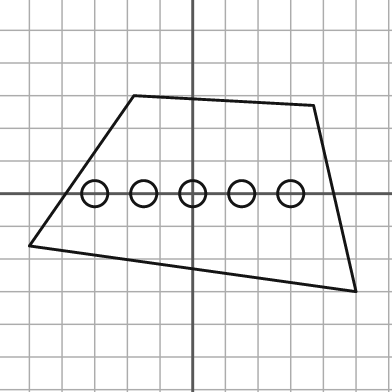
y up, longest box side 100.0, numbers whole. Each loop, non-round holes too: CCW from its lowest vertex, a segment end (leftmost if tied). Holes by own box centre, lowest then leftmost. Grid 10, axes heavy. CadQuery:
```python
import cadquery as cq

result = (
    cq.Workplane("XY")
    .moveTo(50.0, -30.0)
    .lineTo(37.0, 27.0)
    .lineTo(-18.0, 30.0)
    .lineTo(-50.0, -16.0)
    .close()
    .moveTo(-30.0, 0.0)
    .circle(4.0)
    .moveTo(-15.0, 0.0)
    .circle(4.0)
    .moveTo(0.0, 0.0)
    .circle(4.0)
    .moveTo(15.0, 0.0)
    .circle(4.0)
    .moveTo(30.0, 0.0)
    .circle(4.0)
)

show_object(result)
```